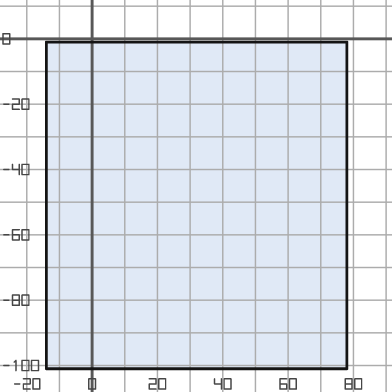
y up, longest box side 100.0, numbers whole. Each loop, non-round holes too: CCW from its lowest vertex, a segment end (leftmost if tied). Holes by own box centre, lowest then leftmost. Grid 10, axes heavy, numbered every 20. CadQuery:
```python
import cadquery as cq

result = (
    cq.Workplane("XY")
    .moveTo(-14.0, -101.0)
    .lineTo(78.0, -101.0)
    .lineTo(78.0, -1.0)
    .lineTo(-14.0, -1.0)
    .close()
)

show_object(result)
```